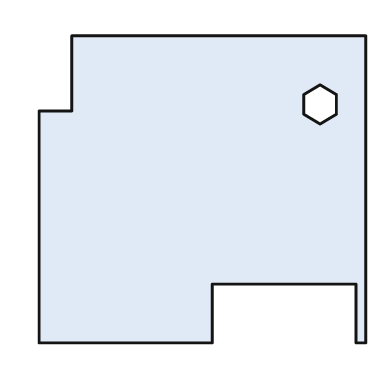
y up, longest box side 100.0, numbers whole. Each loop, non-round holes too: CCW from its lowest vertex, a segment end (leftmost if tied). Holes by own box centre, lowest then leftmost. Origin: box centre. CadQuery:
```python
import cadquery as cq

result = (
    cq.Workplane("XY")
    .moveTo(-50.0, -47.0)
    .lineTo(3.0, -47.0)
    .lineTo(3.0, -29.0)
    .lineTo(47.0, -29.0)
    .lineTo(47.0, -47.0)
    .lineTo(50.0, -47.0)
    .lineTo(50.0, 47.0)
    .lineTo(-40.0, 47.0)
    .lineTo(-40.0, 24.0)
    .lineTo(-50.0, 24.0)
    .close()
    .moveTo(36.0, 20.0)
    .lineTo(41.0, 23.0)
    .lineTo(41.0, 29.0)
    .lineTo(36.0, 32.0)
    .lineTo(31.0, 29.0)
    .lineTo(31.0, 23.0)
    .close()
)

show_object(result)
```